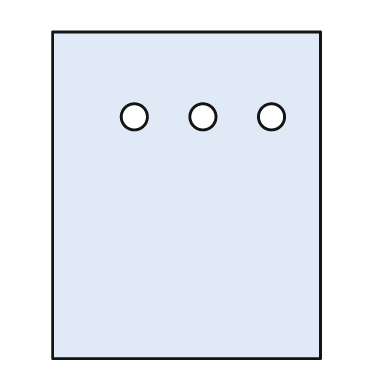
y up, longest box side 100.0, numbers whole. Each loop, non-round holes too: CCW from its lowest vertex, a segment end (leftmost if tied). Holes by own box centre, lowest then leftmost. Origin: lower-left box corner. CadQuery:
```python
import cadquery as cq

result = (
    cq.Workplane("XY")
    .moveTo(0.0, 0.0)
    .lineTo(82.0, 0.0)
    .lineTo(82.0, 100.0)
    .lineTo(0.0, 100.0)
    .close()
    .moveTo(25.0, 74.0)
    .circle(4.0)
    .moveTo(46.0, 74.0)
    .circle(4.0)
    .moveTo(67.0, 74.0)
    .circle(4.0)
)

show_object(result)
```